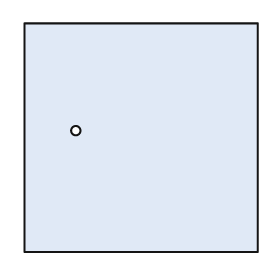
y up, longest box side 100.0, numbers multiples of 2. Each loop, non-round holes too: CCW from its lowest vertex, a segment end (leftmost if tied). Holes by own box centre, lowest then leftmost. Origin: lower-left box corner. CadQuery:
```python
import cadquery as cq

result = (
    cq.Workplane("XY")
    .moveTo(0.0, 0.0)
    .lineTo(100.0, 0.0)
    .lineTo(100.0, 98.0)
    .lineTo(0.0, 98.0)
    .close()
    .moveTo(22.0, 52.0)
    .circle(2.0)
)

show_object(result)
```